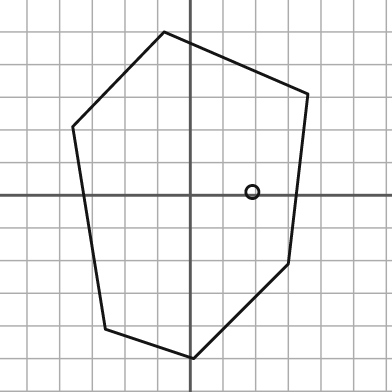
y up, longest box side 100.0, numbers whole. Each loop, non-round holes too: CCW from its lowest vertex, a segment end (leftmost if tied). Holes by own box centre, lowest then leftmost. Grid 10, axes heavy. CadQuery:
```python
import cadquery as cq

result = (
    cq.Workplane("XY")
    .moveTo(1.0, -50.0)
    .lineTo(30.0, -21.0)
    .lineTo(36.0, 31.0)
    .lineTo(-8.0, 50.0)
    .lineTo(-36.0, 21.0)
    .lineTo(-26.0, -41.0)
    .close()
    .moveTo(19.0, 1.0)
    .circle(2.0)
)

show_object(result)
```